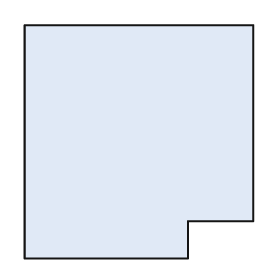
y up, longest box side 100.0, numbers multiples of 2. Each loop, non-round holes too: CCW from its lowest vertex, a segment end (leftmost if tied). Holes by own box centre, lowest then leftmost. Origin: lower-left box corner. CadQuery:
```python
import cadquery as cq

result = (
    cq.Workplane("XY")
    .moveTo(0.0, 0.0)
    .lineTo(70.0, 0.0)
    .lineTo(70.0, 16.0)
    .lineTo(98.0, 16.0)
    .lineTo(98.0, 100.0)
    .lineTo(0.0, 100.0)
    .close()
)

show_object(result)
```